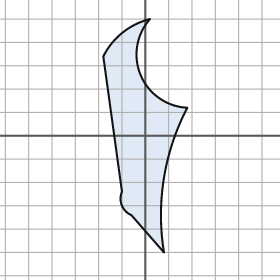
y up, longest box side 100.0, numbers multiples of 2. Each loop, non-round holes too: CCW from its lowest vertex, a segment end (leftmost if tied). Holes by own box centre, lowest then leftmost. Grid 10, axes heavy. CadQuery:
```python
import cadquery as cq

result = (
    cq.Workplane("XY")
    .moveTo(8.0, -50.0)
    .threePointArc((8.0, -18.0), (18.0, 12.0))
    .threePointArc((-2.0, 26.0), (2.0, 50.0))
    .threePointArc((-10.0, 44.0), (-18.0, 34.0))
    .lineTo(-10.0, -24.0)
    .threePointArc((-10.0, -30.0), (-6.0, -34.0))
    .close()
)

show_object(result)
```